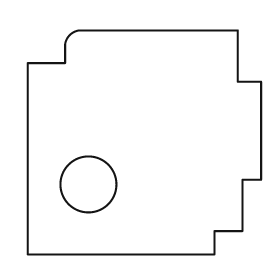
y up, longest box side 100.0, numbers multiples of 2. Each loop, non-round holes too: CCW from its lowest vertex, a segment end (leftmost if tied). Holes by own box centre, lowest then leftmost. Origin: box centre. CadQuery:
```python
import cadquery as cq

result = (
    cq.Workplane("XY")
    .moveTo(-50.0, -48.0)
    .lineTo(30.0, -48.0)
    .lineTo(30.0, -38.0)
    .lineTo(42.0, -38.0)
    .lineTo(42.0, -16.0)
    .lineTo(50.0, -16.0)
    .lineTo(50.0, 26.0)
    .lineTo(40.0, 26.0)
    .lineTo(40.0, 48.0)
    .lineTo(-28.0, 48.0)
    .threePointArc((-32.0, 46.0), (-34.0, 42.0))
    .lineTo(-34.0, 34.0)
    .lineTo(-50.0, 34.0)
    .close()
    .moveTo(-24.0, -18.0)
    .circle(12.0)
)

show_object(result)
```